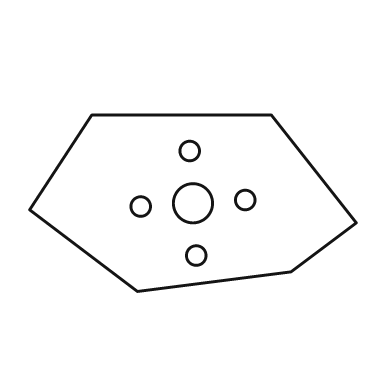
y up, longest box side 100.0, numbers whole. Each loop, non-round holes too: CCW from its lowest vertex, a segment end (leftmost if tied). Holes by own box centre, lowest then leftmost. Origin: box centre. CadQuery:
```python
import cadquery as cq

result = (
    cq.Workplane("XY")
    .moveTo(-17.0, -27.0)
    .lineTo(30.0, -21.0)
    .lineTo(50.0, -6.0)
    .lineTo(24.0, 27.0)
    .lineTo(-31.0, 27.0)
    .lineTo(-50.0, -2.0)
    .close()
    .moveTo(1.0, -16.0)
    .circle(3.0)
    .moveTo(-16.0, -1.0)
    .circle(3.0)
    .moveTo(0.0, 0.0)
    .circle(6.0)
    .moveTo(16.0, 1.0)
    .circle(3.0)
    .moveTo(-1.0, 16.0)
    .circle(3.0)
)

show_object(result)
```